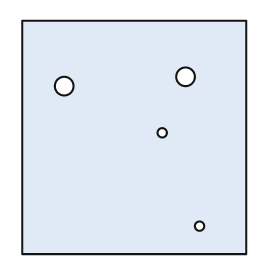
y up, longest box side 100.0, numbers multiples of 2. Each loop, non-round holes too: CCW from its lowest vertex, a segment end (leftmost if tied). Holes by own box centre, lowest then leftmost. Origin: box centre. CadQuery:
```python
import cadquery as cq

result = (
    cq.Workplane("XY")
    .moveTo(-48.0, -50.0)
    .lineTo(48.0, -50.0)
    .lineTo(48.0, 50.0)
    .lineTo(-48.0, 50.0)
    .close()
    .moveTo(28.0, -38.0)
    .circle(2.0)
    .moveTo(12.0, 2.0)
    .circle(2.0)
    .moveTo(-30.0, 22.0)
    .circle(4.0)
    .moveTo(22.0, 26.0)
    .circle(4.0)
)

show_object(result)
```